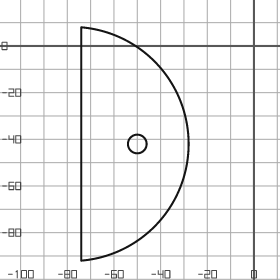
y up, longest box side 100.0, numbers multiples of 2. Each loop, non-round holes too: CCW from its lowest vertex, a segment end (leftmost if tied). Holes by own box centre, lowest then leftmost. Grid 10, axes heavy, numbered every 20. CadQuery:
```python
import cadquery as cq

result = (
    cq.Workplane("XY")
    .moveTo(-74.0, -92.0)
    .threePointArc((-28.0, -42.0), (-74.0, 8.0))
    .close()
    .moveTo(-50.0, -42.0)
    .circle(4.0)
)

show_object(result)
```